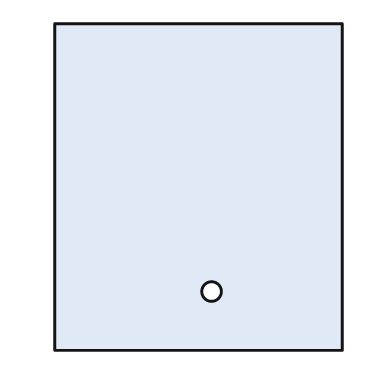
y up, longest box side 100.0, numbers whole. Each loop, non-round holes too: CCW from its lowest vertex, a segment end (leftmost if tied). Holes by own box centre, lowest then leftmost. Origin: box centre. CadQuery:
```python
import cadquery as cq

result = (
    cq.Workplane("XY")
    .moveTo(-44.0, -50.0)
    .lineTo(44.0, -50.0)
    .lineTo(44.0, 50.0)
    .lineTo(-44.0, 50.0)
    .close()
    .moveTo(4.0, -32.0)
    .circle(3.0)
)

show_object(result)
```